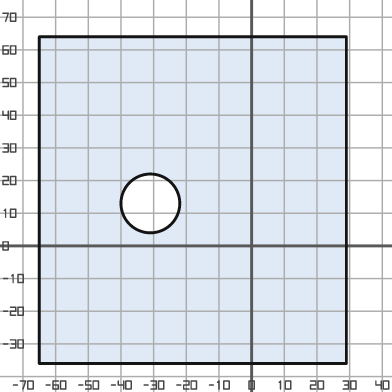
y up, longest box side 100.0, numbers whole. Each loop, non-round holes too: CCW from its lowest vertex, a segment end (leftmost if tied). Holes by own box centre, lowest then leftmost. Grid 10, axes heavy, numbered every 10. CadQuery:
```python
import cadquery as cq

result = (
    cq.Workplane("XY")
    .moveTo(-65.0, -36.0)
    .lineTo(29.0, -36.0)
    .lineTo(29.0, 64.0)
    .lineTo(-65.0, 64.0)
    .close()
    .moveTo(-31.0, 13.0)
    .circle(9.0)
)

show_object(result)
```